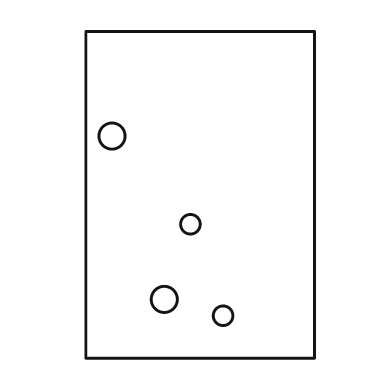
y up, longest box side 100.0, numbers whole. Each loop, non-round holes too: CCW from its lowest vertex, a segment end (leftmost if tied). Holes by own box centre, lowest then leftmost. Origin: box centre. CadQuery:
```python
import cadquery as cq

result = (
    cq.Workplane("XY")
    .moveTo(-35.0, -50.0)
    .lineTo(35.0, -50.0)
    .lineTo(35.0, 50.0)
    .lineTo(-35.0, 50.0)
    .close()
    .moveTo(7.0, -37.0)
    .circle(3.0)
    .moveTo(-11.0, -32.0)
    .circle(4.0)
    .moveTo(-3.0, -9.0)
    .circle(3.0)
    .moveTo(-27.0, 18.0)
    .circle(4.0)
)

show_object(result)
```